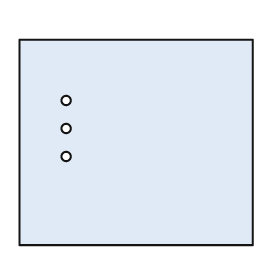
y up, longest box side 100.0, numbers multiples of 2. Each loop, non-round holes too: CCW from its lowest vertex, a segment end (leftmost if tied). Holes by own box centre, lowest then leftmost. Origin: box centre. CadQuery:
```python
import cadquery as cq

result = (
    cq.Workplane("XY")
    .moveTo(-50.0, -44.0)
    .lineTo(50.0, -44.0)
    .lineTo(50.0, 44.0)
    .lineTo(-50.0, 44.0)
    .close()
    .moveTo(-30.0, -6.0)
    .circle(2.0)
    .moveTo(-30.0, 6.0)
    .circle(2.0)
    .moveTo(-30.0, 18.0)
    .circle(2.0)
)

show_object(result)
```